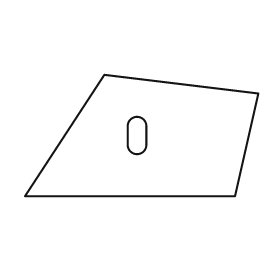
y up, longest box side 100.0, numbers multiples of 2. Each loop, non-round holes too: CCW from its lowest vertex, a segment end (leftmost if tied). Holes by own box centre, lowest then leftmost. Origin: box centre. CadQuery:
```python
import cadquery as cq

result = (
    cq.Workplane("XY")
    .moveTo(-50.0, -26.0)
    .lineTo(40.0, -26.0)
    .lineTo(50.0, 18.0)
    .lineTo(-16.0, 26.0)
    .close()
    .moveTo(-6.0, -4.0)
    .threePointArc((-2.0, -8.0), (2.0, -4.0))
    .lineTo(2.0, 4.0)
    .threePointArc((-2.0, 8.0), (-6.0, 4.0))
    .close()
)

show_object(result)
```